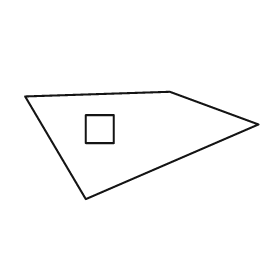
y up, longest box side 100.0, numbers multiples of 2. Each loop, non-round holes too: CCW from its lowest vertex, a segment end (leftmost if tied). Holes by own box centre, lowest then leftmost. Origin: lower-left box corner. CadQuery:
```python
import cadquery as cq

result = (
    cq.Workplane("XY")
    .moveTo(26.0, 0.0)
    .lineTo(100.0, 32.0)
    .lineTo(62.0, 46.0)
    .lineTo(0.0, 44.0)
    .close()
    .moveTo(26.0, 24.0)
    .lineTo(38.0, 24.0)
    .lineTo(38.0, 36.0)
    .lineTo(26.0, 36.0)
    .close()
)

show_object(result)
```